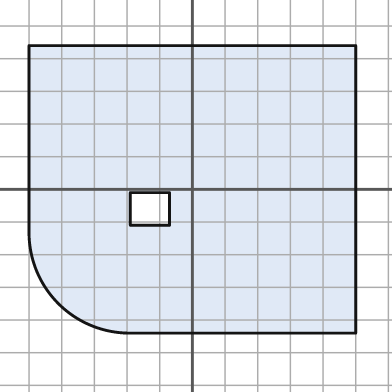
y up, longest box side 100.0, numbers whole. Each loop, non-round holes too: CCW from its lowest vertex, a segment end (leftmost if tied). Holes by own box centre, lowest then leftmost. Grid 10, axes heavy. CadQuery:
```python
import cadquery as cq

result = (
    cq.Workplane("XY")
    .moveTo(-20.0, -44.0)
    .lineTo(50.0, -44.0)
    .lineTo(50.0, 44.0)
    .lineTo(-50.0, 44.0)
    .lineTo(-50.0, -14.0)
    .threePointArc((-41.0, -35.0), (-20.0, -44.0))
    .close()
    .moveTo(-19.0, -11.0)
    .lineTo(-7.0, -11.0)
    .lineTo(-7.0, -1.0)
    .lineTo(-19.0, -1.0)
    .close()
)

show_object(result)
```